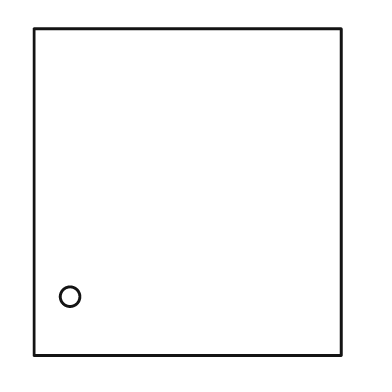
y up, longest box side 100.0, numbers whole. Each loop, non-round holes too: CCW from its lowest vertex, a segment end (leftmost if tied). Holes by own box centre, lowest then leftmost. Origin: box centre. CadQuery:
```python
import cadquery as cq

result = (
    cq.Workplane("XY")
    .moveTo(-47.0, -50.0)
    .lineTo(47.0, -50.0)
    .lineTo(47.0, 50.0)
    .lineTo(-47.0, 50.0)
    .close()
    .moveTo(-36.0, -32.0)
    .circle(3.0)
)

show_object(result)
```